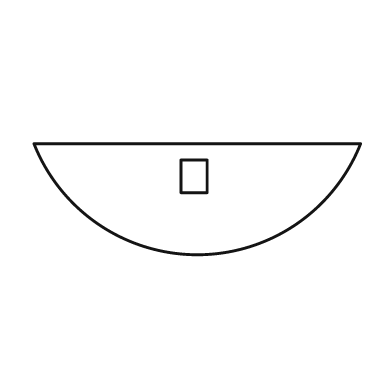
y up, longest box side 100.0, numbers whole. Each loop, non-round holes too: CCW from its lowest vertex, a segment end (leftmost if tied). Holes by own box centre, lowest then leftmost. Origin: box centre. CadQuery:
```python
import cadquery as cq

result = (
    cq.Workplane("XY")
    .moveTo(-50.0, 17.0)
    .threePointArc((0.0, -17.0), (50.0, 17.0))
    .close()
    .moveTo(-5.0, 2.0)
    .lineTo(3.0, 2.0)
    .lineTo(3.0, 12.0)
    .lineTo(-5.0, 12.0)
    .close()
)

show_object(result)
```